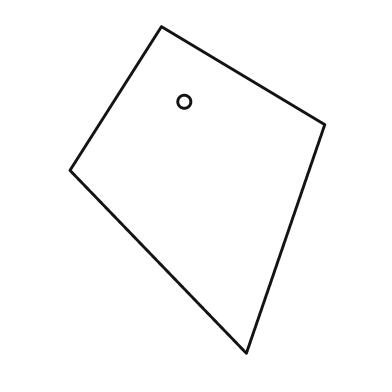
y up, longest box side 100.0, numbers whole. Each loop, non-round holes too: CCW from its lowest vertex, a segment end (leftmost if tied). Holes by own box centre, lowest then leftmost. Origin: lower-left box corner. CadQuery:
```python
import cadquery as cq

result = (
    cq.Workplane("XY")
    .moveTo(54.0, 0.0)
    .lineTo(78.0, 70.0)
    .lineTo(28.0, 100.0)
    .lineTo(0.0, 56.0)
    .close()
    .moveTo(35.0, 77.0)
    .circle(2.0)
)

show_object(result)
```